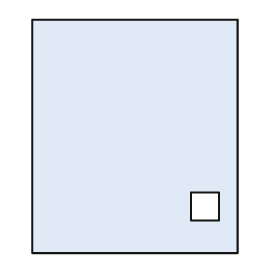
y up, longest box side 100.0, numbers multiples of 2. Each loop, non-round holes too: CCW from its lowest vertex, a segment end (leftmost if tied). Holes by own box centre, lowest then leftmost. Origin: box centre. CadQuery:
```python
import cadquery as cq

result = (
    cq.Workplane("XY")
    .moveTo(-44.0, -50.0)
    .lineTo(44.0, -50.0)
    .lineTo(44.0, 50.0)
    .lineTo(-44.0, 50.0)
    .close()
    .moveTo(24.0, -36.0)
    .lineTo(36.0, -36.0)
    .lineTo(36.0, -24.0)
    .lineTo(24.0, -24.0)
    .close()
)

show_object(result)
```